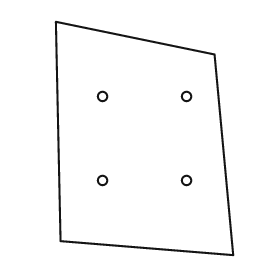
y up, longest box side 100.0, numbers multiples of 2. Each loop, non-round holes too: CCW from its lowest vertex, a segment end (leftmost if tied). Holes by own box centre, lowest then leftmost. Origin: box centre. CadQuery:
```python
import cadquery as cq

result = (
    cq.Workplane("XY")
    .moveTo(38.0, -50.0)
    .lineTo(30.0, 36.0)
    .lineTo(-38.0, 50.0)
    .lineTo(-36.0, -44.0)
    .close()
    .moveTo(-18.0, -18.0)
    .circle(2.0)
    .moveTo(18.0, -18.0)
    .circle(2.0)
    .moveTo(-18.0, 18.0)
    .circle(2.0)
    .moveTo(18.0, 18.0)
    .circle(2.0)
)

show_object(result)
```